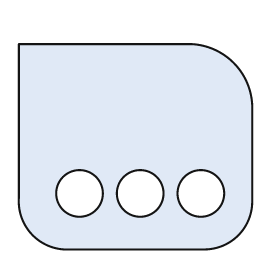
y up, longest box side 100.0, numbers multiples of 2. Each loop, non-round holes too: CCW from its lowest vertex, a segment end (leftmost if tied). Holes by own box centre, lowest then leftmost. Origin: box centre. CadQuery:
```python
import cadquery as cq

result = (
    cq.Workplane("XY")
    .moveTo(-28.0, -44.0)
    .lineTo(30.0, -44.0)
    .threePointArc((44.0, -38.0), (50.0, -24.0))
    .lineTo(50.0, 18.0)
    .threePointArc((42.0, 36.0), (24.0, 44.0))
    .lineTo(-50.0, 44.0)
    .lineTo(-50.0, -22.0)
    .threePointArc((-44.0, -38.0), (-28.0, -44.0))
    .close()
    .moveTo(-24.0, -20.0)
    .circle(10.0)
    .moveTo(2.0, -20.0)
    .circle(10.0)
    .moveTo(28.0, -20.0)
    .circle(10.0)
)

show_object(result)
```